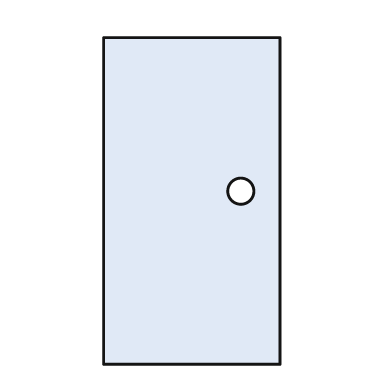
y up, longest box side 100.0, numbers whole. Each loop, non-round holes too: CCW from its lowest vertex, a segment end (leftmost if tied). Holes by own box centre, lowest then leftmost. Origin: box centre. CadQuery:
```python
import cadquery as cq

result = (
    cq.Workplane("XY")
    .moveTo(-27.0, -50.0)
    .lineTo(27.0, -50.0)
    .lineTo(27.0, 50.0)
    .lineTo(-27.0, 50.0)
    .close()
    .moveTo(15.0, 3.0)
    .circle(4.0)
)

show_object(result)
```